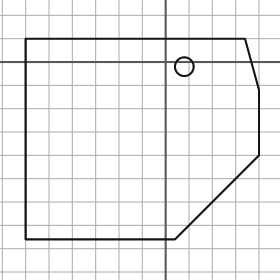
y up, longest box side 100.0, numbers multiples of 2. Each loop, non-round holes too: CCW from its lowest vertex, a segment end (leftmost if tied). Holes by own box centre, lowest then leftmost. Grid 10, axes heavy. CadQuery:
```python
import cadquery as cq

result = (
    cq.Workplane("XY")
    .moveTo(-60.0, -76.0)
    .lineTo(4.0, -76.0)
    .lineTo(40.0, -40.0)
    .lineTo(40.0, -12.0)
    .lineTo(34.0, 10.0)
    .lineTo(-60.0, 10.0)
    .close()
    .moveTo(8.0, -2.0)
    .circle(4.0)
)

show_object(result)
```